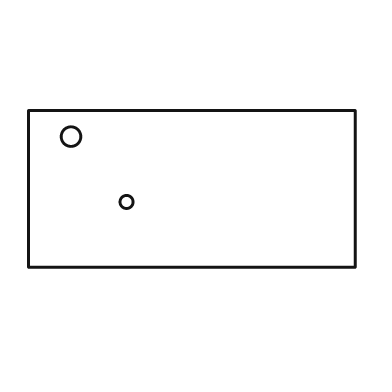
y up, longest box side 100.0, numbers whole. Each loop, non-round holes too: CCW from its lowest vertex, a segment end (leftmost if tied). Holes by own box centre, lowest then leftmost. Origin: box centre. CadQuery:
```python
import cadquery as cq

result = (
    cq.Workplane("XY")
    .moveTo(-50.0, -24.0)
    .lineTo(50.0, -24.0)
    .lineTo(50.0, 24.0)
    .lineTo(-50.0, 24.0)
    .close()
    .moveTo(-20.0, -4.0)
    .circle(2.0)
    .moveTo(-37.0, 16.0)
    .circle(3.0)
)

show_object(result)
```